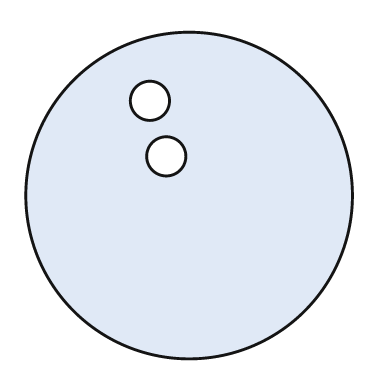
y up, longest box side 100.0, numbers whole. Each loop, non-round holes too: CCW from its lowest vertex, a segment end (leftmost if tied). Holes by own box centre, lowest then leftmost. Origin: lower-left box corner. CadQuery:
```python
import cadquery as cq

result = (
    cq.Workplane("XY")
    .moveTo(50.0, 50.0)
    .circle(50.0)
    .moveTo(43.0, 62.0)
    .circle(6.0)
    .moveTo(38.0, 79.0)
    .circle(6.0)
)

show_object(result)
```